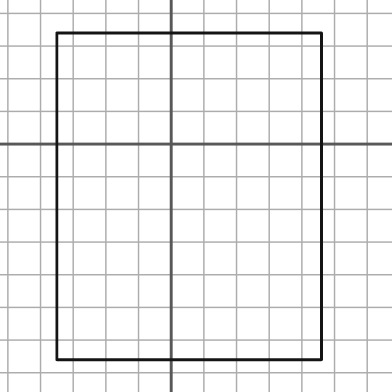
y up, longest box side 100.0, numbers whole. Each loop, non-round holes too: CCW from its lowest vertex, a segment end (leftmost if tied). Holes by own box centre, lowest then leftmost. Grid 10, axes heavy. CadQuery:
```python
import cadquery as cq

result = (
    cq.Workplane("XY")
    .moveTo(-35.0, -66.0)
    .lineTo(46.0, -66.0)
    .lineTo(46.0, 34.0)
    .lineTo(-35.0, 34.0)
    .close()
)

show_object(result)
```